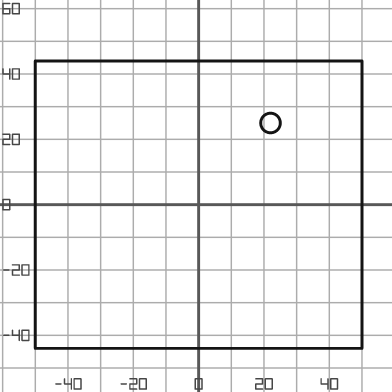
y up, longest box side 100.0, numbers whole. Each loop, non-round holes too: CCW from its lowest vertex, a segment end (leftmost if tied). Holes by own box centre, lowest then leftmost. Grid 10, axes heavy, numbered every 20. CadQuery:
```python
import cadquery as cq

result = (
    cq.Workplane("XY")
    .moveTo(-50.0, -44.0)
    .lineTo(50.0, -44.0)
    .lineTo(50.0, 44.0)
    .lineTo(-50.0, 44.0)
    .close()
    .moveTo(22.0, 25.0)
    .circle(3.0)
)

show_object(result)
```